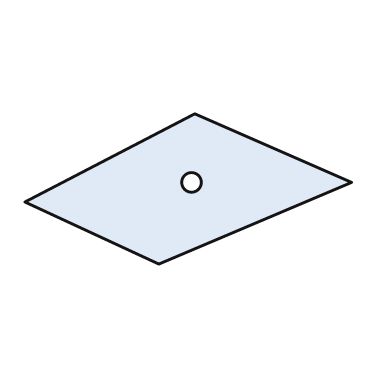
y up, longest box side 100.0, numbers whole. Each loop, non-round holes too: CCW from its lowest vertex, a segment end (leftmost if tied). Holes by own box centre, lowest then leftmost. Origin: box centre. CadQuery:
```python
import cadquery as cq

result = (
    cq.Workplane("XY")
    .moveTo(-9.0, -23.0)
    .lineTo(50.0, 2.0)
    .lineTo(2.0, 23.0)
    .lineTo(-50.0, -4.0)
    .close()
    .moveTo(1.0, 2.0)
    .circle(3.0)
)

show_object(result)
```